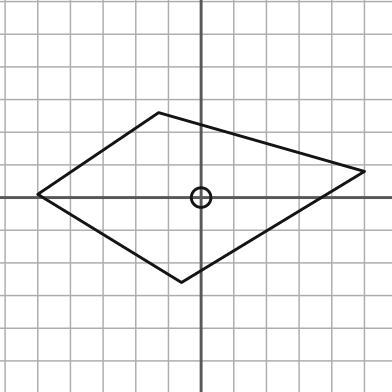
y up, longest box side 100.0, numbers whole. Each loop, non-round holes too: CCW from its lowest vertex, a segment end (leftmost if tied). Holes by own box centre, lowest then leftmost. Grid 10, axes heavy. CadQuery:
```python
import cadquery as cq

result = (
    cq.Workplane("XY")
    .moveTo(-6.0, -26.0)
    .lineTo(50.0, 8.0)
    .lineTo(-13.0, 26.0)
    .lineTo(-50.0, 1.0)
    .close()
    .moveTo(0.0, 0.0)
    .circle(3.0)
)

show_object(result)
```